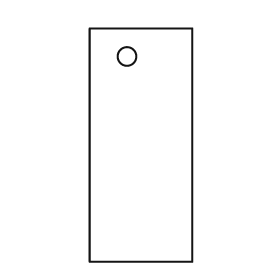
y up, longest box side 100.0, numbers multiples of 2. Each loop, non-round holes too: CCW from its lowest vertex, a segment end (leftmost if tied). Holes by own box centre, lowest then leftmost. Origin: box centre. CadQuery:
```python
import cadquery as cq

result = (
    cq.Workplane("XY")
    .moveTo(-22.0, -50.0)
    .lineTo(22.0, -50.0)
    .lineTo(22.0, 50.0)
    .lineTo(-22.0, 50.0)
    .close()
    .moveTo(-6.0, 38.0)
    .circle(4.0)
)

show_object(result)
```